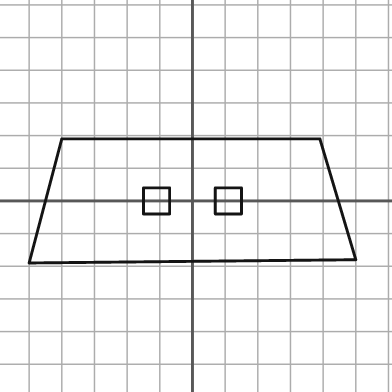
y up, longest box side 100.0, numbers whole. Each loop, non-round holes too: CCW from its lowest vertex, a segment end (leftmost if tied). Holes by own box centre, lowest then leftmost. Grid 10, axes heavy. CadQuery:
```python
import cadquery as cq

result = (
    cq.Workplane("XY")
    .moveTo(-50.0, -19.0)
    .lineTo(50.0, -18.0)
    .lineTo(39.0, 19.0)
    .lineTo(-40.0, 19.0)
    .close()
    .moveTo(-15.0, -4.0)
    .lineTo(-7.0, -4.0)
    .lineTo(-7.0, 4.0)
    .lineTo(-15.0, 4.0)
    .close()
    .moveTo(7.0, -4.0)
    .lineTo(15.0, -4.0)
    .lineTo(15.0, 4.0)
    .lineTo(7.0, 4.0)
    .close()
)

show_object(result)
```